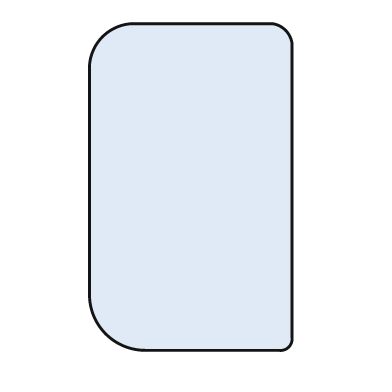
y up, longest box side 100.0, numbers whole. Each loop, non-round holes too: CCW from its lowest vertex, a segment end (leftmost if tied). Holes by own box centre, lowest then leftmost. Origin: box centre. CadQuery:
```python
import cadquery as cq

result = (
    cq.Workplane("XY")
    .moveTo(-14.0, -50.0)
    .lineTo(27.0, -50.0)
    .threePointArc((30.0, -49.0), (31.0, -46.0))
    .lineTo(31.0, 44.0)
    .threePointArc((29.0, 48.0), (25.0, 50.0))
    .lineTo(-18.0, 50.0)
    .threePointArc((-27.0, 46.0), (-31.0, 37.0))
    .lineTo(-31.0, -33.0)
    .threePointArc((-26.0, -45.0), (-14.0, -50.0))
    .close()
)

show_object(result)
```